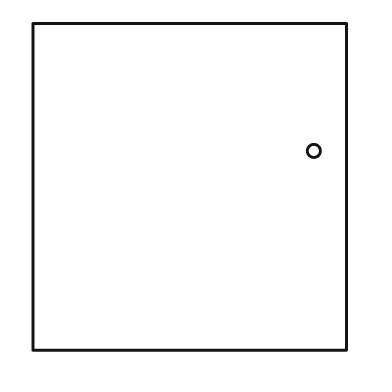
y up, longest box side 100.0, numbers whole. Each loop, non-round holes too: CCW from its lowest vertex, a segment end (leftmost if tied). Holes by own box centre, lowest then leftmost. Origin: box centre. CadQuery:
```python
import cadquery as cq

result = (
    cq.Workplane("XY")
    .moveTo(-48.0, -50.0)
    .lineTo(48.0, -50.0)
    .lineTo(48.0, 50.0)
    .lineTo(-48.0, 50.0)
    .close()
    .moveTo(38.0, 11.0)
    .circle(2.0)
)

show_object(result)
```